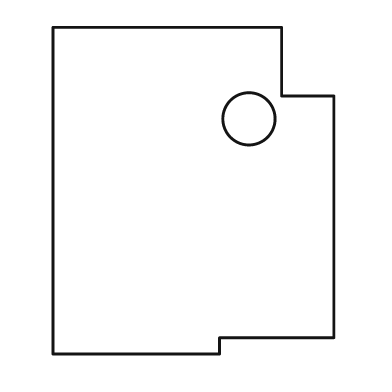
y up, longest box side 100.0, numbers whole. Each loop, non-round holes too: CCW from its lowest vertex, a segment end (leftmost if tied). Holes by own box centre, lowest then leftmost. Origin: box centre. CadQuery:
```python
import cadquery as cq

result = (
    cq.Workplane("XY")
    .moveTo(-43.0, -50.0)
    .lineTo(8.0, -50.0)
    .lineTo(8.0, -45.0)
    .lineTo(43.0, -45.0)
    .lineTo(43.0, 29.0)
    .lineTo(27.0, 29.0)
    .lineTo(27.0, 50.0)
    .lineTo(-43.0, 50.0)
    .close()
    .moveTo(17.0, 22.0)
    .circle(8.0)
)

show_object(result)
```